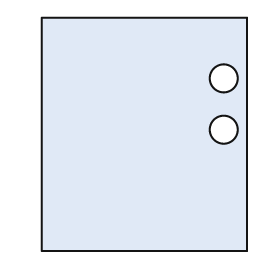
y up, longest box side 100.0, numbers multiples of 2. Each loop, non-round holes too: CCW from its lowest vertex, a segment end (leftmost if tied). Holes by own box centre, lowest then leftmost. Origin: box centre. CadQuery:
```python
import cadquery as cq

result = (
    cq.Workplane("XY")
    .moveTo(-44.0, -50.0)
    .lineTo(44.0, -50.0)
    .lineTo(44.0, 50.0)
    .lineTo(-44.0, 50.0)
    .close()
    .moveTo(34.0, 2.0)
    .circle(6.0)
    .moveTo(34.0, 24.0)
    .circle(6.0)
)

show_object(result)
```